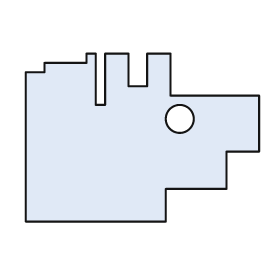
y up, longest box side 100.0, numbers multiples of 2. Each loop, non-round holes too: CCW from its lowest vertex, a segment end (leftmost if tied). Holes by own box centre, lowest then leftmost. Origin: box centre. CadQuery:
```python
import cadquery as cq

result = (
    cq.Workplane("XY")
    .moveTo(-50.0, -36.0)
    .lineTo(10.0, -36.0)
    .lineTo(10.0, -22.0)
    .lineTo(36.0, -22.0)
    .lineTo(36.0, -6.0)
    .lineTo(50.0, -6.0)
    .lineTo(50.0, 18.0)
    .lineTo(12.0, 18.0)
    .lineTo(12.0, 36.0)
    .lineTo(2.0, 36.0)
    .lineTo(2.0, 22.0)
    .lineTo(-6.0, 22.0)
    .lineTo(-6.0, 36.0)
    .lineTo(-16.0, 36.0)
    .lineTo(-16.0, 14.0)
    .lineTo(-20.0, 14.0)
    .lineTo(-20.0, 36.0)
    .lineTo(-24.0, 36.0)
    .lineTo(-24.0, 32.0)
    .lineTo(-42.0, 32.0)
    .lineTo(-42.0, 28.0)
    .lineTo(-50.0, 28.0)
    .close()
    .moveTo(16.0, 8.0)
    .circle(6.0)
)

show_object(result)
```